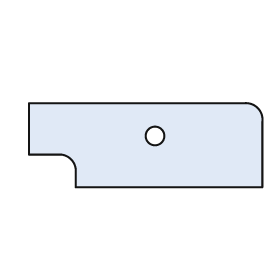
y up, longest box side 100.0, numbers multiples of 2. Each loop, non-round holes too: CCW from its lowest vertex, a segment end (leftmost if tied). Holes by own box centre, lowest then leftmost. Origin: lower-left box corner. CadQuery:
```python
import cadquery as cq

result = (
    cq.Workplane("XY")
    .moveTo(20.0, 0.0)
    .lineTo(100.0, 0.0)
    .lineTo(100.0, 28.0)
    .threePointArc((98.0, 34.0), (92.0, 36.0))
    .lineTo(0.0, 36.0)
    .lineTo(0.0, 14.0)
    .lineTo(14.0, 14.0)
    .threePointArc((18.0, 12.0), (20.0, 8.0))
    .close()
    .moveTo(54.0, 22.0)
    .circle(4.0)
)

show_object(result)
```